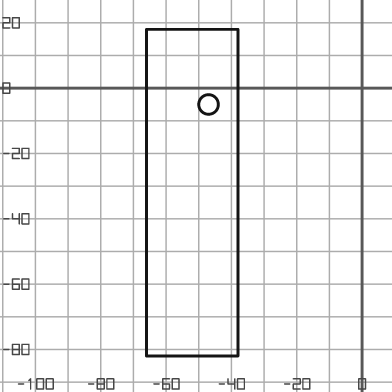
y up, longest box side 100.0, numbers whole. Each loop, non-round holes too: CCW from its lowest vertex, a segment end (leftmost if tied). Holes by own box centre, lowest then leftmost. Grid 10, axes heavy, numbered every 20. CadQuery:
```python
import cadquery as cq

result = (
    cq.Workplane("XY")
    .moveTo(-66.0, -82.0)
    .lineTo(-38.0, -82.0)
    .lineTo(-38.0, 18.0)
    .lineTo(-66.0, 18.0)
    .close()
    .moveTo(-47.0, -5.0)
    .circle(3.0)
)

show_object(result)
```